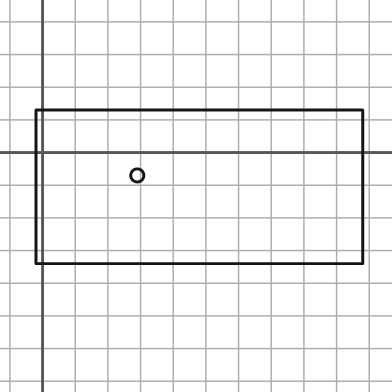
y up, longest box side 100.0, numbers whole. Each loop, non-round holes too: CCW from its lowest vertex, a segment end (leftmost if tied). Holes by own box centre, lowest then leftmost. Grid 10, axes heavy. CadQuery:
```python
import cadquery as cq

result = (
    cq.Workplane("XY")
    .moveTo(-2.0, -34.0)
    .lineTo(98.0, -34.0)
    .lineTo(98.0, 13.0)
    .lineTo(-2.0, 13.0)
    .close()
    .moveTo(29.0, -7.0)
    .circle(2.0)
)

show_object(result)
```